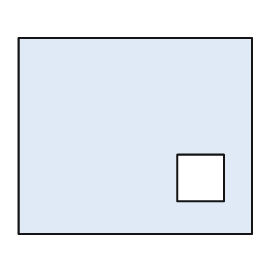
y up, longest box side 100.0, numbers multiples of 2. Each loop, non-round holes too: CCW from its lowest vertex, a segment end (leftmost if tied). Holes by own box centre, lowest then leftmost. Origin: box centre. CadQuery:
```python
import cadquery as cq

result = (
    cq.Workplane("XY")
    .moveTo(-50.0, -42.0)
    .lineTo(50.0, -42.0)
    .lineTo(50.0, 42.0)
    .lineTo(-50.0, 42.0)
    .close()
    .moveTo(18.0, -28.0)
    .lineTo(38.0, -28.0)
    .lineTo(38.0, -8.0)
    .lineTo(18.0, -8.0)
    .close()
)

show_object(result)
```